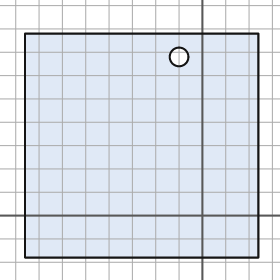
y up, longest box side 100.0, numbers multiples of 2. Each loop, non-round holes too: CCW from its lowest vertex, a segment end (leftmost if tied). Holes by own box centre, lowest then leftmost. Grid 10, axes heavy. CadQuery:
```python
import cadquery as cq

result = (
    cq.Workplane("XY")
    .moveTo(-76.0, -18.0)
    .lineTo(24.0, -18.0)
    .lineTo(24.0, 78.0)
    .lineTo(-76.0, 78.0)
    .close()
    .moveTo(-10.0, 68.0)
    .circle(4.0)
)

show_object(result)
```